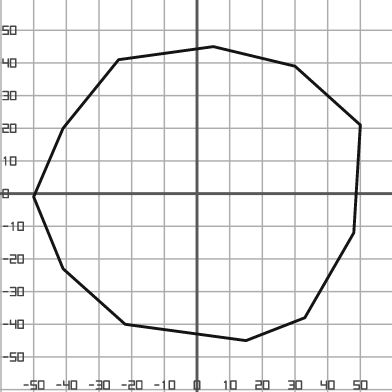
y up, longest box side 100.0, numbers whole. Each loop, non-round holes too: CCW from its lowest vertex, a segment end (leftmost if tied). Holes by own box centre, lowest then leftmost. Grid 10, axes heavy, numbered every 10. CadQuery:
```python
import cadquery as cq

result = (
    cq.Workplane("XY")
    .moveTo(15.0, -45.0)
    .lineTo(33.0, -38.0)
    .lineTo(48.0, -12.0)
    .lineTo(50.0, 21.0)
    .lineTo(30.0, 39.0)
    .lineTo(5.0, 45.0)
    .lineTo(-24.0, 41.0)
    .lineTo(-41.0, 20.0)
    .lineTo(-50.0, -1.0)
    .lineTo(-41.0, -23.0)
    .lineTo(-22.0, -40.0)
    .close()
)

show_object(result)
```